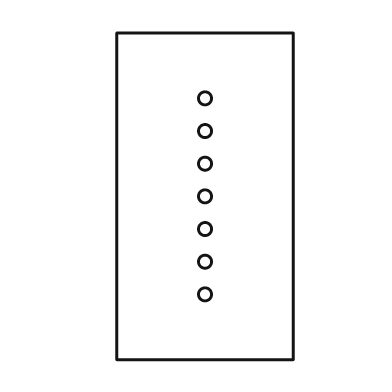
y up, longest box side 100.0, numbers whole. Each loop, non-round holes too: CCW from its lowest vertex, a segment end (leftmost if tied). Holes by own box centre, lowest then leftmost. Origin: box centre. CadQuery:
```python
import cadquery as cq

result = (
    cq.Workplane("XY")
    .moveTo(-27.0, -50.0)
    .lineTo(27.0, -50.0)
    .lineTo(27.0, 50.0)
    .lineTo(-27.0, 50.0)
    .close()
    .moveTo(0.0, -30.0)
    .circle(2.0)
    .moveTo(0.0, -20.0)
    .circle(2.0)
    .moveTo(0.0, -10.0)
    .circle(2.0)
    .moveTo(0.0, 0.0)
    .circle(2.0)
    .moveTo(0.0, 10.0)
    .circle(2.0)
    .moveTo(0.0, 20.0)
    .circle(2.0)
    .moveTo(0.0, 30.0)
    .circle(2.0)
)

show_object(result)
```